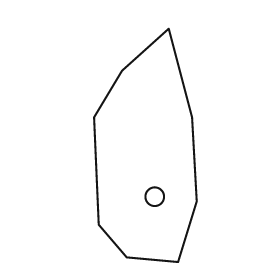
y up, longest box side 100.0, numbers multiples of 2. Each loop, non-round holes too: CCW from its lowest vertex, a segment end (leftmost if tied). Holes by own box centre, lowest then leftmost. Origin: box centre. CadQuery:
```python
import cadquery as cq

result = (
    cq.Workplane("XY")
    .moveTo(14.0, -50.0)
    .lineTo(22.0, -24.0)
    .lineTo(20.0, 12.0)
    .lineTo(10.0, 50.0)
    .lineTo(-10.0, 32.0)
    .lineTo(-22.0, 12.0)
    .lineTo(-20.0, -34.0)
    .lineTo(-8.0, -48.0)
    .close()
    .moveTo(4.0, -22.0)
    .circle(4.0)
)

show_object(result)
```